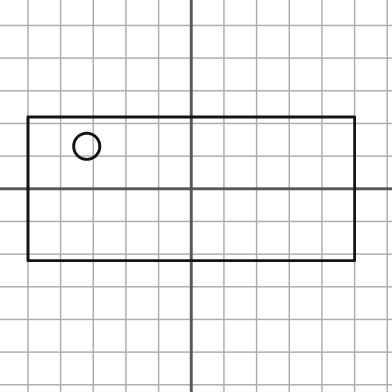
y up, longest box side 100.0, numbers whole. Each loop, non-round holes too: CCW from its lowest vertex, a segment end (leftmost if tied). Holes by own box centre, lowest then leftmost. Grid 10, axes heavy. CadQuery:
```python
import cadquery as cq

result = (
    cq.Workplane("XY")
    .moveTo(-50.0, -22.0)
    .lineTo(50.0, -22.0)
    .lineTo(50.0, 22.0)
    .lineTo(-50.0, 22.0)
    .close()
    .moveTo(-32.0, 13.0)
    .circle(4.0)
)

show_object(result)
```